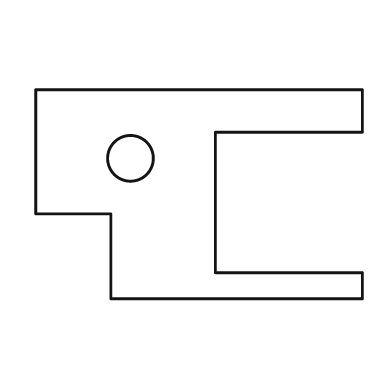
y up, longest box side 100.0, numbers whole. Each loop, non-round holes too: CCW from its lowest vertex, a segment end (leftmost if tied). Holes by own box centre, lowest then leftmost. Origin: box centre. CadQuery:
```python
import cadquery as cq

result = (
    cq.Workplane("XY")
    .moveTo(-27.0, -32.0)
    .lineTo(50.0, -32.0)
    .lineTo(50.0, -24.0)
    .lineTo(5.0, -24.0)
    .lineTo(5.0, 19.0)
    .lineTo(50.0, 19.0)
    .lineTo(50.0, 32.0)
    .lineTo(-50.0, 32.0)
    .lineTo(-50.0, -6.0)
    .lineTo(-27.0, -6.0)
    .close()
    .moveTo(-21.0, 11.0)
    .circle(7.0)
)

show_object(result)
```